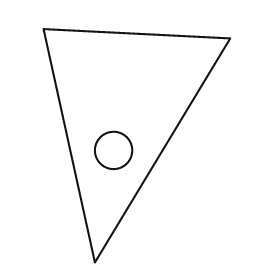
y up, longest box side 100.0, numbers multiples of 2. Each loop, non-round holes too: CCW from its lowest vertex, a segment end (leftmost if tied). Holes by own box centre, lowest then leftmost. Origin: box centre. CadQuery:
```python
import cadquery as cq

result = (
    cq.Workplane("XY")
    .moveTo(-18.0, -50.0)
    .lineTo(40.0, 46.0)
    .lineTo(-40.0, 50.0)
    .close()
    .moveTo(-10.0, -2.0)
    .circle(8.0)
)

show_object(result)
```